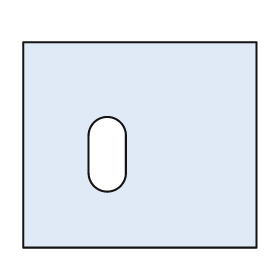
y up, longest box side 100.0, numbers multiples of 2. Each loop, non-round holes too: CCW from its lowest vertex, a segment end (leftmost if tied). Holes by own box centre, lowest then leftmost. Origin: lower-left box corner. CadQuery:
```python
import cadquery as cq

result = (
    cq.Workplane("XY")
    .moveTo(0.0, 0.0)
    .lineTo(100.0, 0.0)
    .lineTo(100.0, 88.0)
    .lineTo(0.0, 88.0)
    .close()
    .moveTo(28.0, 32.0)
    .threePointArc((36.0, 24.0), (44.0, 32.0))
    .lineTo(44.0, 48.0)
    .threePointArc((36.0, 56.0), (28.0, 48.0))
    .close()
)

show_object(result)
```